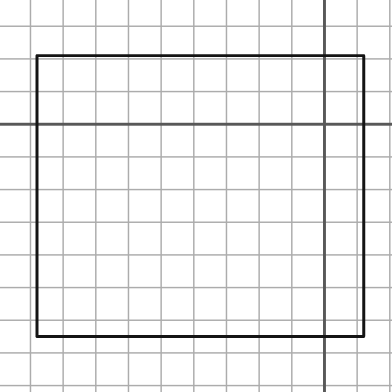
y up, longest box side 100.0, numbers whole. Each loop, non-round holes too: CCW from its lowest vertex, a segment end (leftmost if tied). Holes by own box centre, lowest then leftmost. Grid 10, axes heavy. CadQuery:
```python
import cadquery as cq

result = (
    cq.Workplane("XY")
    .moveTo(-88.0, -65.0)
    .lineTo(12.0, -65.0)
    .lineTo(12.0, 21.0)
    .lineTo(-88.0, 21.0)
    .close()
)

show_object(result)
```